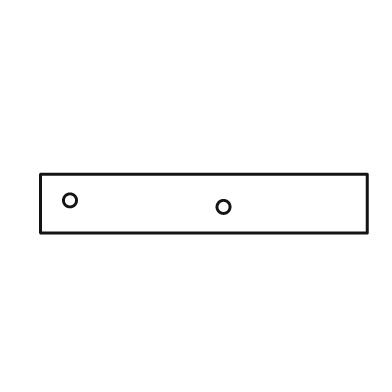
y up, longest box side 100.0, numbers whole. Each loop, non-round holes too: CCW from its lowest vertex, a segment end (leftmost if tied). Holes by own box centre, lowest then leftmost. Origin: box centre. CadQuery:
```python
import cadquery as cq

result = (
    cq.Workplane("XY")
    .moveTo(-50.0, -9.0)
    .lineTo(50.0, -9.0)
    .lineTo(50.0, 9.0)
    .lineTo(-50.0, 9.0)
    .close()
    .moveTo(6.0, -1.0)
    .circle(2.0)
    .moveTo(-41.0, 1.0)
    .circle(2.0)
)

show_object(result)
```